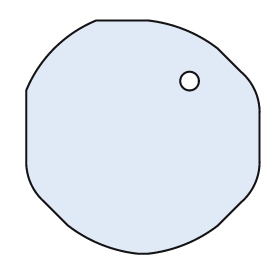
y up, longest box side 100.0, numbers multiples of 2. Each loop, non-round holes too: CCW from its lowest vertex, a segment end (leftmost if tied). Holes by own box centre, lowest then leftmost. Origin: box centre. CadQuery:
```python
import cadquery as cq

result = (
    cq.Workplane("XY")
    .moveTo(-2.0, -50.0)
    .lineTo(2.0, -50.0)
    .threePointArc((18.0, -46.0), (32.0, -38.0))
    .lineTo(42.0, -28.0)
    .threePointArc((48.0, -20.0), (50.0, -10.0))
    .lineTo(50.0, 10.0)
    .threePointArc((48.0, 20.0), (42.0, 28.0))
    .lineTo(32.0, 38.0)
    .threePointArc((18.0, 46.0), (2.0, 50.0))
    .lineTo(-20.0, 50.0)
    .threePointArc((-38.0, 38.0), (-50.0, 20.0))
    .lineTo(-50.0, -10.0)
    .threePointArc((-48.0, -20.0), (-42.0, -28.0))
    .lineTo(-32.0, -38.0)
    .threePointArc((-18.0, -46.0), (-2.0, -50.0))
    .close()
    .moveTo(20.0, 24.0)
    .circle(4.0)
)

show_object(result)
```